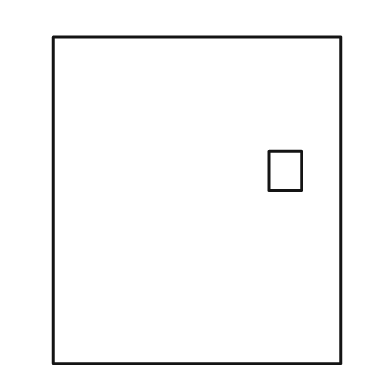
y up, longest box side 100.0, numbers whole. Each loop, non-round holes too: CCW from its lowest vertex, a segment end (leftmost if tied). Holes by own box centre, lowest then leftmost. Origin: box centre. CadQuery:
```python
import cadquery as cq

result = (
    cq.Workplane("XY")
    .moveTo(-44.0, -50.0)
    .lineTo(44.0, -50.0)
    .lineTo(44.0, 50.0)
    .lineTo(-44.0, 50.0)
    .close()
    .moveTo(22.0, 3.0)
    .lineTo(32.0, 3.0)
    .lineTo(32.0, 15.0)
    .lineTo(22.0, 15.0)
    .close()
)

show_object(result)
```